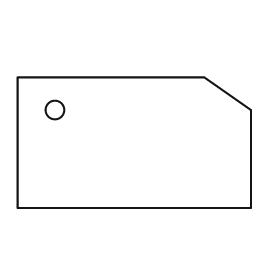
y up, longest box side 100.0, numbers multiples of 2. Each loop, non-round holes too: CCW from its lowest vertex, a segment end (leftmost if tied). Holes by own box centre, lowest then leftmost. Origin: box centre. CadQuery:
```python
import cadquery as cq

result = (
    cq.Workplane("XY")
    .moveTo(-50.0, -28.0)
    .lineTo(50.0, -28.0)
    .lineTo(50.0, 14.0)
    .lineTo(30.0, 28.0)
    .lineTo(-50.0, 28.0)
    .close()
    .moveTo(-34.0, 14.0)
    .circle(4.0)
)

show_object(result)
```